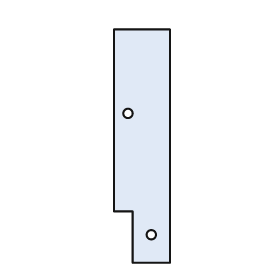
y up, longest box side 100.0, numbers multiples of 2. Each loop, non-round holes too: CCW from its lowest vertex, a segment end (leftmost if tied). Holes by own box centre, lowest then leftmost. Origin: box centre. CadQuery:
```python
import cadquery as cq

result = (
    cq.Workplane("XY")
    .moveTo(-4.0, -50.0)
    .lineTo(12.0, -50.0)
    .lineTo(12.0, 50.0)
    .lineTo(-12.0, 50.0)
    .lineTo(-12.0, -28.0)
    .lineTo(-4.0, -28.0)
    .close()
    .moveTo(4.0, -38.0)
    .circle(2.0)
    .moveTo(-6.0, 14.0)
    .circle(2.0)
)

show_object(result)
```